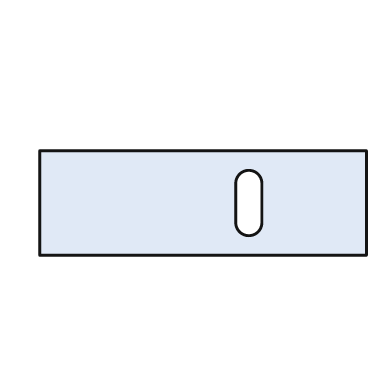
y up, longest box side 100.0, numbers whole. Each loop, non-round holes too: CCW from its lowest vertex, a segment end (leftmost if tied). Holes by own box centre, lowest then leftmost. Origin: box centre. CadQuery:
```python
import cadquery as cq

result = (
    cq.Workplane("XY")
    .moveTo(-50.0, -16.0)
    .lineTo(50.0, -16.0)
    .lineTo(50.0, 16.0)
    .lineTo(-50.0, 16.0)
    .close()
    .moveTo(10.0, -6.0)
    .threePointArc((14.0, -10.0), (18.0, -6.0))
    .lineTo(18.0, 6.0)
    .threePointArc((14.0, 10.0), (10.0, 6.0))
    .close()
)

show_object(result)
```